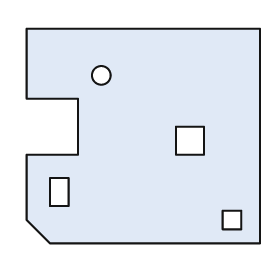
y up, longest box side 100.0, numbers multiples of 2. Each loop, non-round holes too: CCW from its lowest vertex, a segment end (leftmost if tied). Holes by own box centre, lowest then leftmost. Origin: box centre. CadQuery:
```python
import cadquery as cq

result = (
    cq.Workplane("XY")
    .moveTo(-40.0, -46.0)
    .lineTo(50.0, -46.0)
    .lineTo(50.0, 46.0)
    .lineTo(-50.0, 46.0)
    .lineTo(-50.0, 16.0)
    .lineTo(-28.0, 16.0)
    .lineTo(-28.0, -8.0)
    .lineTo(-50.0, -8.0)
    .lineTo(-50.0, -36.0)
    .close()
    .moveTo(34.0, -40.0)
    .lineTo(42.0, -40.0)
    .lineTo(42.0, -32.0)
    .lineTo(34.0, -32.0)
    .close()
    .moveTo(-40.0, -30.0)
    .lineTo(-32.0, -30.0)
    .lineTo(-32.0, -18.0)
    .lineTo(-40.0, -18.0)
    .close()
    .moveTo(14.0, -8.0)
    .lineTo(26.0, -8.0)
    .lineTo(26.0, 4.0)
    .lineTo(14.0, 4.0)
    .close()
    .moveTo(-18.0, 26.0)
    .circle(4.0)
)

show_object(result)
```